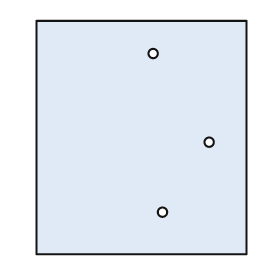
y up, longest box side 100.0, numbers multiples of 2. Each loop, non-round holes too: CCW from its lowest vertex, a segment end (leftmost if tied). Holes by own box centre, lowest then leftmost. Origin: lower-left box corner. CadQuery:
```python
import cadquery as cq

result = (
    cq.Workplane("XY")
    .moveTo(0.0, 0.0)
    .lineTo(90.0, 0.0)
    .lineTo(90.0, 100.0)
    .lineTo(0.0, 100.0)
    .close()
    .moveTo(54.0, 18.0)
    .circle(2.0)
    .moveTo(74.0, 48.0)
    .circle(2.0)
    .moveTo(50.0, 86.0)
    .circle(2.0)
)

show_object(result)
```